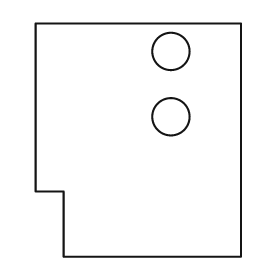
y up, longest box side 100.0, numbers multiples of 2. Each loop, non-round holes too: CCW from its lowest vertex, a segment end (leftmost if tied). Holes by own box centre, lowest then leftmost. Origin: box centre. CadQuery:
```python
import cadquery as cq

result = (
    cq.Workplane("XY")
    .moveTo(-32.0, -50.0)
    .lineTo(44.0, -50.0)
    .lineTo(44.0, 50.0)
    .lineTo(-44.0, 50.0)
    .lineTo(-44.0, -22.0)
    .lineTo(-32.0, -22.0)
    .close()
    .moveTo(14.0, 10.0)
    .circle(8.0)
    .moveTo(14.0, 38.0)
    .circle(8.0)
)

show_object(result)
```